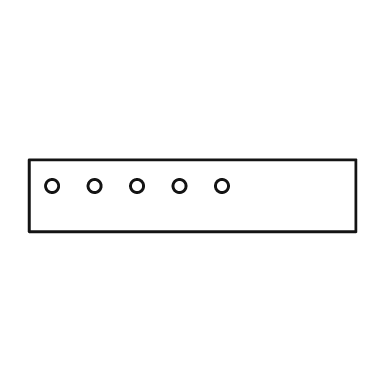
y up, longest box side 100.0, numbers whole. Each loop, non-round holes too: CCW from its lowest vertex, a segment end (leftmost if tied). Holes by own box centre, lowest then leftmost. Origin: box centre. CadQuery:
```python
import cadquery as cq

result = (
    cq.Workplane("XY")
    .moveTo(-50.0, -11.0)
    .lineTo(50.0, -11.0)
    .lineTo(50.0, 11.0)
    .lineTo(-50.0, 11.0)
    .close()
    .moveTo(-43.0, 3.0)
    .circle(2.0)
    .moveTo(-30.0, 3.0)
    .circle(2.0)
    .moveTo(-17.0, 3.0)
    .circle(2.0)
    .moveTo(-4.0, 3.0)
    .circle(2.0)
    .moveTo(9.0, 3.0)
    .circle(2.0)
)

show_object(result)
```